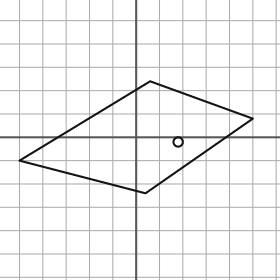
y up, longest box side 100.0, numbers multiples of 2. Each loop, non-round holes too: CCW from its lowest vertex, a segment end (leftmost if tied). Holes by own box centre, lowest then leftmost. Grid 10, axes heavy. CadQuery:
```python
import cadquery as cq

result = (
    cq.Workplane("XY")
    .moveTo(4.0, -24.0)
    .lineTo(50.0, 8.0)
    .lineTo(6.0, 24.0)
    .lineTo(-50.0, -10.0)
    .close()
    .moveTo(18.0, -2.0)
    .circle(2.0)
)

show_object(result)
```